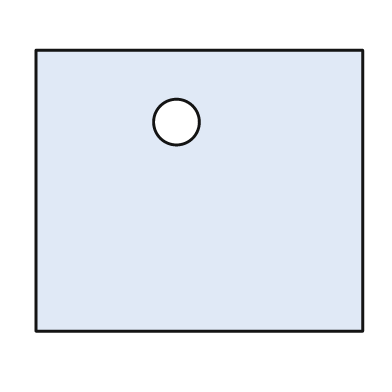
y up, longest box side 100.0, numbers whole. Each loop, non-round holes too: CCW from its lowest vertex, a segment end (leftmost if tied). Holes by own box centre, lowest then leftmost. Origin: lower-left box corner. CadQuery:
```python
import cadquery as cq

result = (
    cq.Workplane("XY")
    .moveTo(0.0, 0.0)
    .lineTo(100.0, 0.0)
    .lineTo(100.0, 86.0)
    .lineTo(0.0, 86.0)
    .close()
    .moveTo(43.0, 64.0)
    .circle(7.0)
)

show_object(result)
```